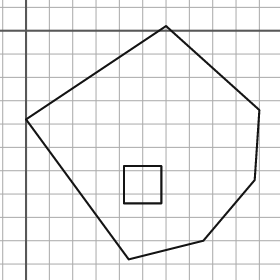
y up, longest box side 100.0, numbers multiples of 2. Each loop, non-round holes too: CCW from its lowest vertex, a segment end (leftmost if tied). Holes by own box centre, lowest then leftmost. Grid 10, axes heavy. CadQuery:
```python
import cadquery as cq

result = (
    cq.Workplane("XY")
    .moveTo(44.0, -98.0)
    .lineTo(76.0, -90.0)
    .lineTo(98.0, -64.0)
    .lineTo(100.0, -34.0)
    .lineTo(60.0, 2.0)
    .lineTo(0.0, -38.0)
    .close()
    .moveTo(42.0, -74.0)
    .lineTo(58.0, -74.0)
    .lineTo(58.0, -58.0)
    .lineTo(42.0, -58.0)
    .close()
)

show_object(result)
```